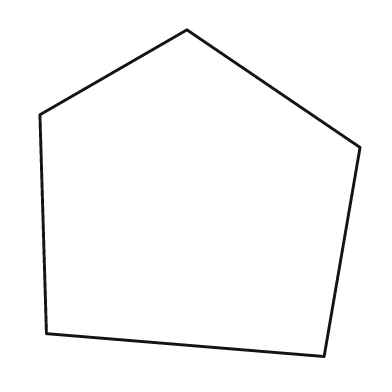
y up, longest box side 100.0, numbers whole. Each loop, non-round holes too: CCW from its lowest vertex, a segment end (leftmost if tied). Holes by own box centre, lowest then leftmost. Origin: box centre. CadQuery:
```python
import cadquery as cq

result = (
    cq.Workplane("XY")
    .moveTo(38.0, -50.0)
    .lineTo(49.0, 14.0)
    .lineTo(-4.0, 50.0)
    .lineTo(-49.0, 24.0)
    .lineTo(-47.0, -43.0)
    .close()
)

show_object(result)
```